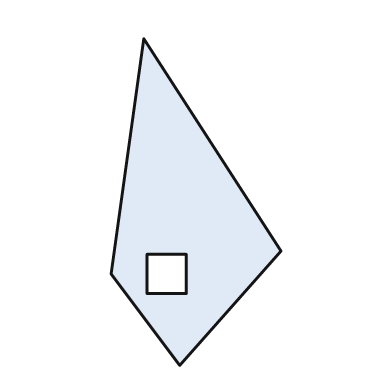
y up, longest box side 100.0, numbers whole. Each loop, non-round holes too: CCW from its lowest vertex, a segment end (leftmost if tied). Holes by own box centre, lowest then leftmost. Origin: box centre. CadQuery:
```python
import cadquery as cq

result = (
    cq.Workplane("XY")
    .moveTo(-5.0, -50.0)
    .lineTo(26.0, -15.0)
    .lineTo(-16.0, 50.0)
    .lineTo(-26.0, -22.0)
    .close()
    .moveTo(-15.0, -28.0)
    .lineTo(-3.0, -28.0)
    .lineTo(-3.0, -16.0)
    .lineTo(-15.0, -16.0)
    .close()
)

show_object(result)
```